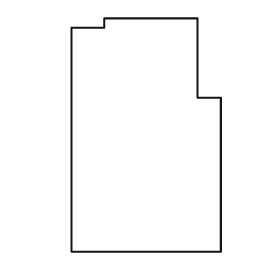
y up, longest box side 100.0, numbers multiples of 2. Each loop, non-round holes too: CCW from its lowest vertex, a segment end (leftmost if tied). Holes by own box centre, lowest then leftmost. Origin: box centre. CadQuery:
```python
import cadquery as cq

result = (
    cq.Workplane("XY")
    .moveTo(-32.0, -50.0)
    .lineTo(32.0, -50.0)
    .lineTo(32.0, 16.0)
    .lineTo(22.0, 16.0)
    .lineTo(22.0, 50.0)
    .lineTo(-18.0, 50.0)
    .lineTo(-18.0, 46.0)
    .lineTo(-32.0, 46.0)
    .close()
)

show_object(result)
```